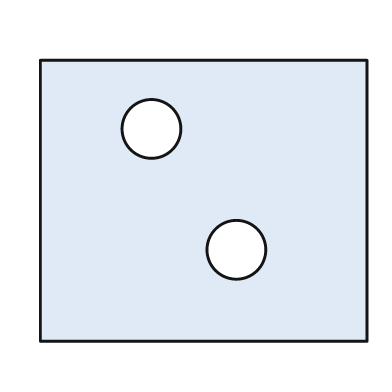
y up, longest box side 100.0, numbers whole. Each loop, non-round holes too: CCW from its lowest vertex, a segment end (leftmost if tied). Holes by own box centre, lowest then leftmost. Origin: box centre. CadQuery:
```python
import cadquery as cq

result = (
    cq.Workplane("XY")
    .moveTo(-50.0, -43.0)
    .lineTo(50.0, -43.0)
    .lineTo(50.0, 43.0)
    .lineTo(-50.0, 43.0)
    .close()
    .moveTo(10.0, -15.0)
    .circle(9.0)
    .moveTo(-16.0, 22.0)
    .circle(9.0)
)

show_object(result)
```